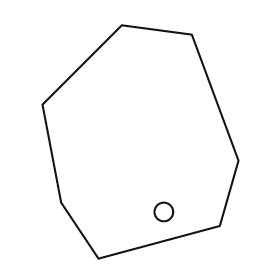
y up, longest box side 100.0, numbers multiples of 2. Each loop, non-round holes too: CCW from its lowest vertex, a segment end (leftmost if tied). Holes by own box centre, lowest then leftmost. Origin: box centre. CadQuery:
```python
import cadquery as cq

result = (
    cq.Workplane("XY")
    .moveTo(-18.0, -50.0)
    .lineTo(34.0, -36.0)
    .lineTo(42.0, -8.0)
    .lineTo(22.0, 46.0)
    .lineTo(-8.0, 50.0)
    .lineTo(-42.0, 16.0)
    .lineTo(-34.0, -26.0)
    .close()
    .moveTo(10.0, -30.0)
    .circle(4.0)
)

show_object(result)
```